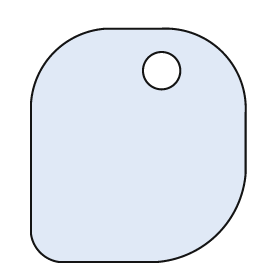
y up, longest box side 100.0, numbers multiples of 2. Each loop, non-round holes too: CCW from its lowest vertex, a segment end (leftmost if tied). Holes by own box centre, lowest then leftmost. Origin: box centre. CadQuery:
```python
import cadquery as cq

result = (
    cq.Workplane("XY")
    .moveTo(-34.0, -50.0)
    .lineTo(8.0, -50.0)
    .threePointArc((34.0, -38.0), (46.0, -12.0))
    .lineTo(46.0, 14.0)
    .threePointArc((36.0, 40.0), (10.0, 50.0))
    .lineTo(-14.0, 50.0)
    .threePointArc((-36.0, 40.0), (-46.0, 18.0))
    .lineTo(-46.0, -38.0)
    .threePointArc((-42.0, -46.0), (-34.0, -50.0))
    .close()
    .moveTo(10.0, 32.0)
    .circle(8.0)
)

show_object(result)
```